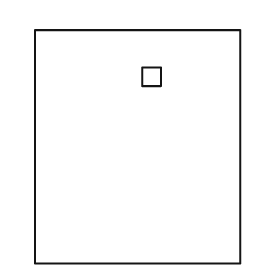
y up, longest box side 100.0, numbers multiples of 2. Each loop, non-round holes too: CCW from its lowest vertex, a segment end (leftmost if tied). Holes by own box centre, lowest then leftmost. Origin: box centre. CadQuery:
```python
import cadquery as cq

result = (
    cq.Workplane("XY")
    .moveTo(-44.0, -50.0)
    .lineTo(44.0, -50.0)
    .lineTo(44.0, 50.0)
    .lineTo(-44.0, 50.0)
    .close()
    .moveTo(2.0, 26.0)
    .lineTo(10.0, 26.0)
    .lineTo(10.0, 34.0)
    .lineTo(2.0, 34.0)
    .close()
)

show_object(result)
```